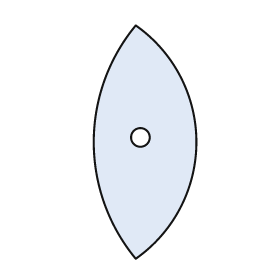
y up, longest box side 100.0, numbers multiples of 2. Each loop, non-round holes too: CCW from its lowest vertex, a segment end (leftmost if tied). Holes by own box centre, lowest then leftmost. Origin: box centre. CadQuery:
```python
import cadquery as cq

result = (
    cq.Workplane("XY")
    .moveTo(-4.0, -50.0)
    .threePointArc((22.0, 0.0), (-4.0, 50.0))
    .threePointArc((-22.0, 0.0), (-4.0, -50.0))
    .close()
    .moveTo(-2.0, 2.0)
    .circle(4.0)
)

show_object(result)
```